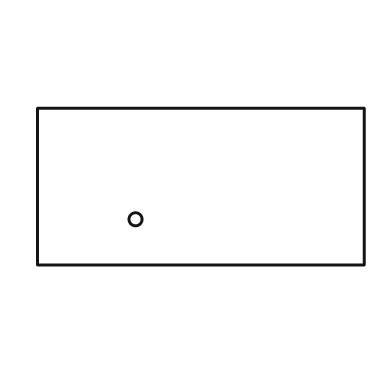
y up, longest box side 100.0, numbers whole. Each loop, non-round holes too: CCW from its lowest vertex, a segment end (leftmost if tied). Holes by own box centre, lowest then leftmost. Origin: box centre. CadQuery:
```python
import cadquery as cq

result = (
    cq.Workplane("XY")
    .moveTo(-50.0, -24.0)
    .lineTo(50.0, -24.0)
    .lineTo(50.0, 24.0)
    .lineTo(-50.0, 24.0)
    .close()
    .moveTo(-20.0, -10.0)
    .circle(2.0)
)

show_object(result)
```